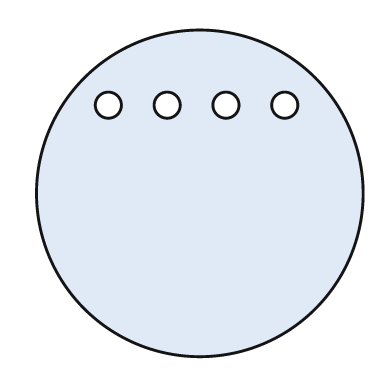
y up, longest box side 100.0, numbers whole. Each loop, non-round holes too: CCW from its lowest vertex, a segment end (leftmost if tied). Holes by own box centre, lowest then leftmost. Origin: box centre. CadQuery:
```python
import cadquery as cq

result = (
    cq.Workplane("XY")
    .moveTo(0.0, 0.0)
    .circle(50.0)
    .moveTo(-28.0, 27.0)
    .circle(4.0)
    .moveTo(-10.0, 27.0)
    .circle(4.0)
    .moveTo(8.0, 27.0)
    .circle(4.0)
    .moveTo(26.0, 27.0)
    .circle(4.0)
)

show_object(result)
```